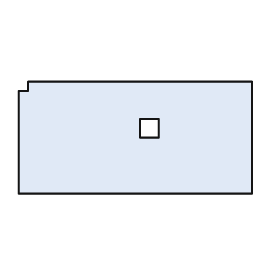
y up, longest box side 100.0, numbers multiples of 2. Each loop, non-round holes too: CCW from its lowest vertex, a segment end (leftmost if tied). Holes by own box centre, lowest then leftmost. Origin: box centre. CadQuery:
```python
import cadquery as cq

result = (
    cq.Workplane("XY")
    .moveTo(-50.0, -24.0)
    .lineTo(50.0, -24.0)
    .lineTo(50.0, 24.0)
    .lineTo(-46.0, 24.0)
    .lineTo(-46.0, 20.0)
    .lineTo(-50.0, 20.0)
    .close()
    .moveTo(2.0, 0.0)
    .lineTo(10.0, 0.0)
    .lineTo(10.0, 8.0)
    .lineTo(2.0, 8.0)
    .close()
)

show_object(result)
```